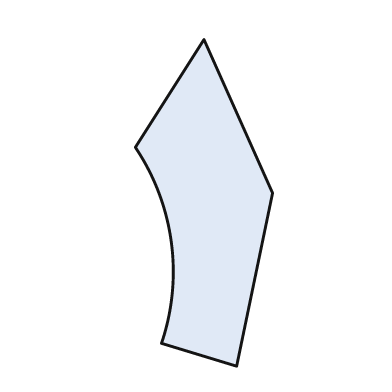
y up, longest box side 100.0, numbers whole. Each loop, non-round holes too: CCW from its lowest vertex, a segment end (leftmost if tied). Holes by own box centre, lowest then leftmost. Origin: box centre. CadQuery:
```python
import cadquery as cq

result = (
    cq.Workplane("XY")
    .moveTo(10.0, -50.0)
    .lineTo(21.0, 3.0)
    .lineTo(0.0, 50.0)
    .lineTo(-21.0, 17.0)
    .threePointArc((-10.0, -12.0), (-13.0, -43.0))
    .close()
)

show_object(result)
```